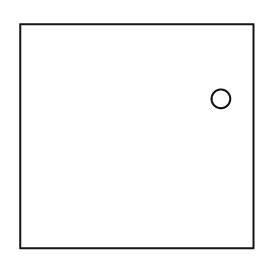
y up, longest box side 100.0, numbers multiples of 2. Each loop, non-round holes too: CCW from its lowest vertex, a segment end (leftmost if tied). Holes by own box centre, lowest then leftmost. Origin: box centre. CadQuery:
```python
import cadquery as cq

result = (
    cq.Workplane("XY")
    .moveTo(-50.0, -48.0)
    .lineTo(50.0, -48.0)
    .lineTo(50.0, 48.0)
    .lineTo(-50.0, 48.0)
    .close()
    .moveTo(36.0, 16.0)
    .circle(4.0)
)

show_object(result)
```